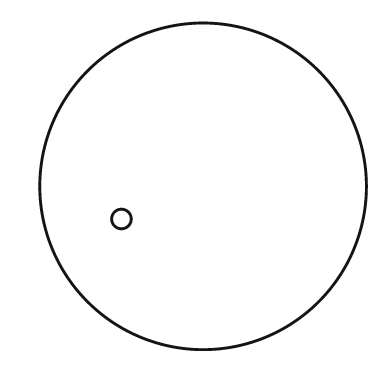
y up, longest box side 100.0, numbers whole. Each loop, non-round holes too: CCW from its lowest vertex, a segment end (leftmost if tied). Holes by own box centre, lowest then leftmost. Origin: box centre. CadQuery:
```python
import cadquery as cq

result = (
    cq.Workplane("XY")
    .moveTo(0.0, 0.0)
    .circle(50.0)
    .moveTo(-25.0, -10.0)
    .circle(3.0)
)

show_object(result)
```